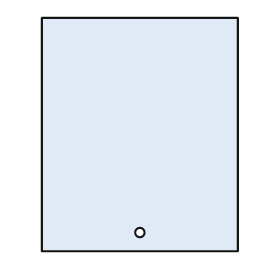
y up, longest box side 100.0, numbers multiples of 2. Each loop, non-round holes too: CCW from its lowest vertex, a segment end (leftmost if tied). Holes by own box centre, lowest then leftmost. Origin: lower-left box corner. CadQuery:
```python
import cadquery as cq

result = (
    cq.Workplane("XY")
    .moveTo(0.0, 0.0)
    .lineTo(84.0, 0.0)
    .lineTo(84.0, 100.0)
    .lineTo(0.0, 100.0)
    .close()
    .moveTo(42.0, 8.0)
    .circle(2.0)
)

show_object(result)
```